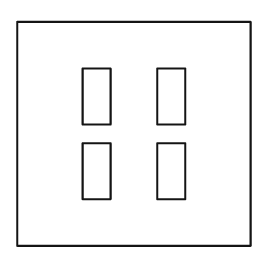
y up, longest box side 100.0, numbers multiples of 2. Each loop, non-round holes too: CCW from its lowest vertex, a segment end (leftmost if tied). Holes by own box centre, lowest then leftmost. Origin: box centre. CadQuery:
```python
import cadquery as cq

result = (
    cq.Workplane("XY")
    .moveTo(-50.0, -48.0)
    .lineTo(50.0, -48.0)
    .lineTo(50.0, 48.0)
    .lineTo(-50.0, 48.0)
    .close()
    .moveTo(-22.0, -28.0)
    .lineTo(-10.0, -28.0)
    .lineTo(-10.0, -4.0)
    .lineTo(-22.0, -4.0)
    .close()
    .moveTo(10.0, -28.0)
    .lineTo(22.0, -28.0)
    .lineTo(22.0, -4.0)
    .lineTo(10.0, -4.0)
    .close()
    .moveTo(-22.0, 4.0)
    .lineTo(-10.0, 4.0)
    .lineTo(-10.0, 28.0)
    .lineTo(-22.0, 28.0)
    .close()
    .moveTo(10.0, 4.0)
    .lineTo(22.0, 4.0)
    .lineTo(22.0, 28.0)
    .lineTo(10.0, 28.0)
    .close()
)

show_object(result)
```